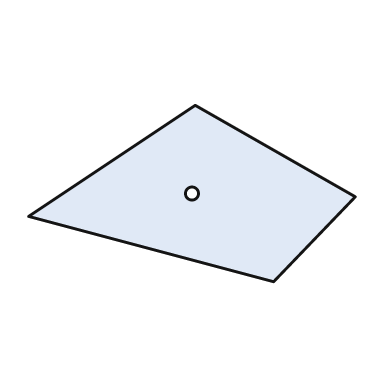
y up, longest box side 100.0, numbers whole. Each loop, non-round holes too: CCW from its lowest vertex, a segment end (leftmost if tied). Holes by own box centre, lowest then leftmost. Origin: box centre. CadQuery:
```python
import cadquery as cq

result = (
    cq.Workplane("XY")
    .moveTo(25.0, -27.0)
    .lineTo(50.0, -1.0)
    .lineTo(1.0, 27.0)
    .lineTo(-50.0, -7.0)
    .close()
    .moveTo(0.0, 0.0)
    .circle(2.0)
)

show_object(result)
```